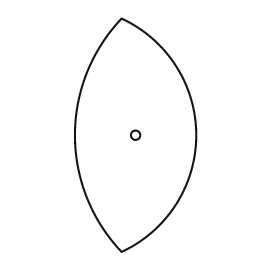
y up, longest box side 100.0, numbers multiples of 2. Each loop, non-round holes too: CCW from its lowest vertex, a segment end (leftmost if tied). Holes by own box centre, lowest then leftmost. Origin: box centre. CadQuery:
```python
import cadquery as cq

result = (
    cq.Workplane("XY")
    .moveTo(-6.0, -50.0)
    .threePointArc((26.0, 0.0), (-6.0, 50.0))
    .threePointArc((-26.0, 0.0), (-6.0, -50.0))
    .close()
    .moveTo(0.0, 0.0)
    .circle(2.0)
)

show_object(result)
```